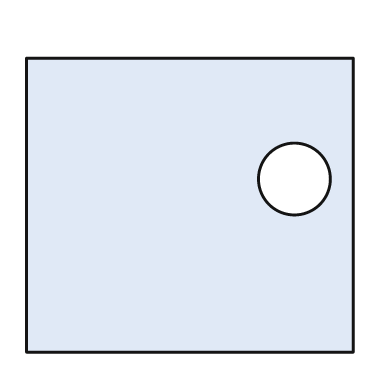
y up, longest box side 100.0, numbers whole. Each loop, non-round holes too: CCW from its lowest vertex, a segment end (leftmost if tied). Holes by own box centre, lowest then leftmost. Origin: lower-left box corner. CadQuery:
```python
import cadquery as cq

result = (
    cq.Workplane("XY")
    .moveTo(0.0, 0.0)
    .lineTo(100.0, 0.0)
    .lineTo(100.0, 90.0)
    .lineTo(0.0, 90.0)
    .close()
    .moveTo(82.0, 53.0)
    .circle(11.0)
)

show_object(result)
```